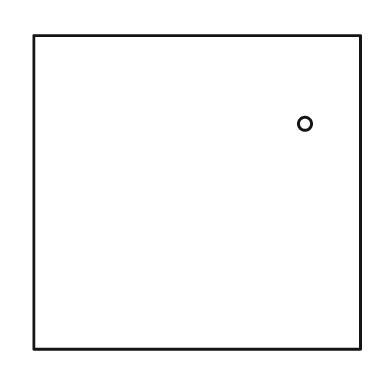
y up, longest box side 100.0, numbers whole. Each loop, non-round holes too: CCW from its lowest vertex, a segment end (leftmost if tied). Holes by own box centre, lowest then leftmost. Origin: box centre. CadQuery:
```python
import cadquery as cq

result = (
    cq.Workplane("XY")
    .moveTo(-50.0, -48.0)
    .lineTo(50.0, -48.0)
    .lineTo(50.0, 48.0)
    .lineTo(-50.0, 48.0)
    .close()
    .moveTo(33.0, 21.0)
    .circle(2.0)
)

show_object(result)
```